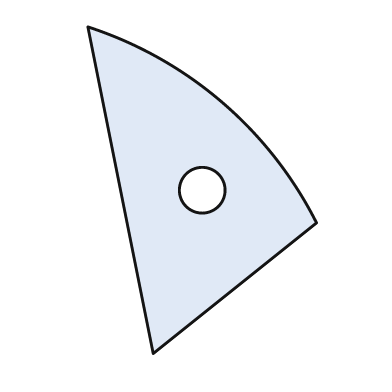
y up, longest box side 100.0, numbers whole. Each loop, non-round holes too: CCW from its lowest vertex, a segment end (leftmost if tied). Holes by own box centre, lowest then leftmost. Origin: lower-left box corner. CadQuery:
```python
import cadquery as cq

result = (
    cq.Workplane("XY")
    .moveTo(20.0, 0.0)
    .lineTo(70.0, 40.0)
    .threePointArc((41.0, 77.0), (0.0, 100.0))
    .close()
    .moveTo(35.0, 50.0)
    .circle(7.0)
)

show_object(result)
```